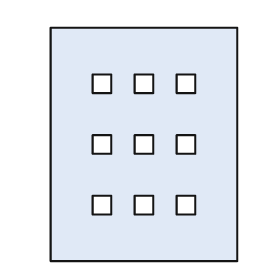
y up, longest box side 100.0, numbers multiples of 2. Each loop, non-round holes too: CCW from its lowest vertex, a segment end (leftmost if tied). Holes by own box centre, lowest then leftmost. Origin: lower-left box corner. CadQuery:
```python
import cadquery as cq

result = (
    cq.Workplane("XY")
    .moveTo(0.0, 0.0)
    .lineTo(80.0, 0.0)
    .lineTo(80.0, 100.0)
    .lineTo(0.0, 100.0)
    .close()
    .moveTo(18.0, 20.0)
    .lineTo(26.0, 20.0)
    .lineTo(26.0, 28.0)
    .lineTo(18.0, 28.0)
    .close()
    .moveTo(36.0, 20.0)
    .lineTo(44.0, 20.0)
    .lineTo(44.0, 28.0)
    .lineTo(36.0, 28.0)
    .close()
    .moveTo(54.0, 20.0)
    .lineTo(62.0, 20.0)
    .lineTo(62.0, 28.0)
    .lineTo(54.0, 28.0)
    .close()
    .moveTo(18.0, 46.0)
    .lineTo(26.0, 46.0)
    .lineTo(26.0, 54.0)
    .lineTo(18.0, 54.0)
    .close()
    .moveTo(36.0, 46.0)
    .lineTo(44.0, 46.0)
    .lineTo(44.0, 54.0)
    .lineTo(36.0, 54.0)
    .close()
    .moveTo(54.0, 46.0)
    .lineTo(62.0, 46.0)
    .lineTo(62.0, 54.0)
    .lineTo(54.0, 54.0)
    .close()
    .moveTo(18.0, 72.0)
    .lineTo(26.0, 72.0)
    .lineTo(26.0, 80.0)
    .lineTo(18.0, 80.0)
    .close()
    .moveTo(36.0, 72.0)
    .lineTo(44.0, 72.0)
    .lineTo(44.0, 80.0)
    .lineTo(36.0, 80.0)
    .close()
    .moveTo(54.0, 72.0)
    .lineTo(62.0, 72.0)
    .lineTo(62.0, 80.0)
    .lineTo(54.0, 80.0)
    .close()
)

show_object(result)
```